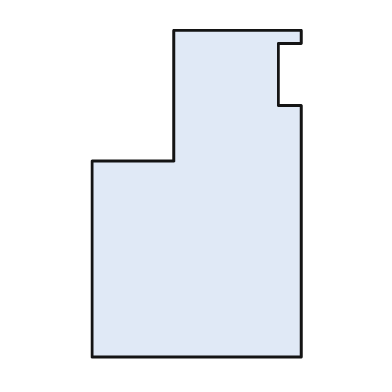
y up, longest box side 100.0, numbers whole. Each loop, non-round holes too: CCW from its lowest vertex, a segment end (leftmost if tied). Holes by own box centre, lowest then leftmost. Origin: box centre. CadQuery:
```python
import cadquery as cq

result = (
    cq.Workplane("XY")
    .moveTo(-32.0, -50.0)
    .lineTo(32.0, -50.0)
    .lineTo(32.0, 27.0)
    .lineTo(25.0, 27.0)
    .lineTo(25.0, 46.0)
    .lineTo(32.0, 46.0)
    .lineTo(32.0, 50.0)
    .lineTo(-7.0, 50.0)
    .lineTo(-7.0, 10.0)
    .lineTo(-32.0, 10.0)
    .close()
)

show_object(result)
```